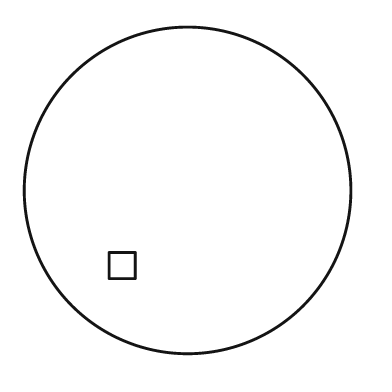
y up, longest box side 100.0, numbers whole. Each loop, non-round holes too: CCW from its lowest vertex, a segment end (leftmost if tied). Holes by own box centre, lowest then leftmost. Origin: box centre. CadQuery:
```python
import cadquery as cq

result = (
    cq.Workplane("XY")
    .moveTo(0.0, 0.0)
    .circle(50.0)
    .moveTo(-24.0, -27.0)
    .lineTo(-16.0, -27.0)
    .lineTo(-16.0, -19.0)
    .lineTo(-24.0, -19.0)
    .close()
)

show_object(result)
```